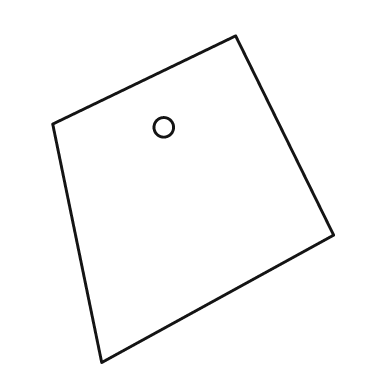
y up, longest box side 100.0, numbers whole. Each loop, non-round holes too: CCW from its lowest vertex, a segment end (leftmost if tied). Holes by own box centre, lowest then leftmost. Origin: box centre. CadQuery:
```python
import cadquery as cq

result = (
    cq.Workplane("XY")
    .moveTo(-28.0, -50.0)
    .lineTo(43.0, -11.0)
    .lineTo(13.0, 50.0)
    .lineTo(-43.0, 23.0)
    .close()
    .moveTo(-9.0, 22.0)
    .circle(3.0)
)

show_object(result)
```